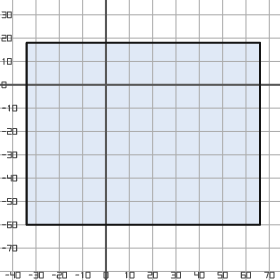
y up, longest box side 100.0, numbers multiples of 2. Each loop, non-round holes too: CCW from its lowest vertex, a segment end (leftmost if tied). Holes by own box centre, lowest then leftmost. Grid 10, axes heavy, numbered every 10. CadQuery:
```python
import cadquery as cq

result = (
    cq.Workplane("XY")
    .moveTo(-34.0, -60.0)
    .lineTo(66.0, -60.0)
    .lineTo(66.0, 18.0)
    .lineTo(-34.0, 18.0)
    .close()
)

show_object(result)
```